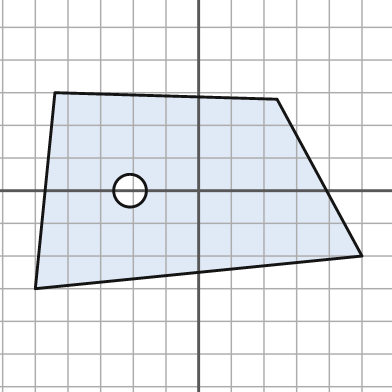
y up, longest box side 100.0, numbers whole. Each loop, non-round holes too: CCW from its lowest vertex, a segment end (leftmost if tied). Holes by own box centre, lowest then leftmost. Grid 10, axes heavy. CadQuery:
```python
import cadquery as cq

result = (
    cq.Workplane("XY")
    .moveTo(-50.0, -30.0)
    .lineTo(50.0, -20.0)
    .lineTo(24.0, 28.0)
    .lineTo(-44.0, 30.0)
    .close()
    .moveTo(-21.0, 0.0)
    .circle(5.0)
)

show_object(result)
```